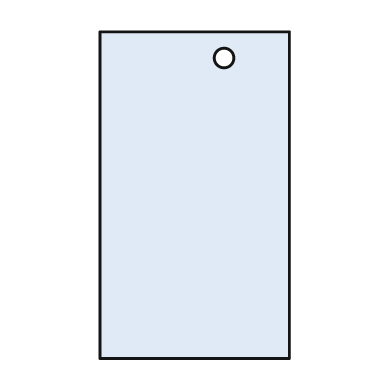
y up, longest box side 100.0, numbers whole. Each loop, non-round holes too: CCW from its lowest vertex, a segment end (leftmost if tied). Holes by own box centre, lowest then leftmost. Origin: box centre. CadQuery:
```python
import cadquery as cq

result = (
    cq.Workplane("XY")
    .moveTo(-29.0, -50.0)
    .lineTo(29.0, -50.0)
    .lineTo(29.0, 50.0)
    .lineTo(-29.0, 50.0)
    .close()
    .moveTo(9.0, 42.0)
    .circle(3.0)
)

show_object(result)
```